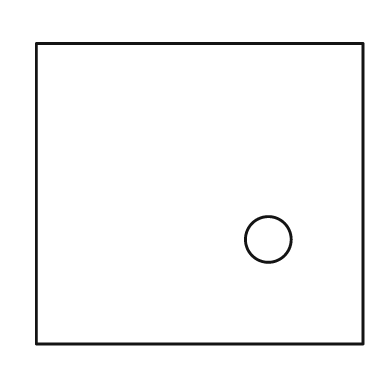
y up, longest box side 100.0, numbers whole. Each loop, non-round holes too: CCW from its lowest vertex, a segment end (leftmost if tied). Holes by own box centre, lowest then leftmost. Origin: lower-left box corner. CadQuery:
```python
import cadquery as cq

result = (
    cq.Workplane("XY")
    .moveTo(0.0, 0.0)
    .lineTo(100.0, 0.0)
    .lineTo(100.0, 92.0)
    .lineTo(0.0, 92.0)
    .close()
    .moveTo(71.0, 32.0)
    .circle(7.0)
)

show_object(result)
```